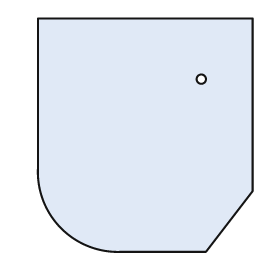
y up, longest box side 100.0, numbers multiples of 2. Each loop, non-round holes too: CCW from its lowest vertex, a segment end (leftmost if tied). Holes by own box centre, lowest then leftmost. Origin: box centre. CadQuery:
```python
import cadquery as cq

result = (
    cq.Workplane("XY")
    .moveTo(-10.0, -50.0)
    .lineTo(26.0, -50.0)
    .lineTo(46.0, -24.0)
    .lineTo(46.0, 50.0)
    .lineTo(-46.0, 50.0)
    .lineTo(-46.0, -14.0)
    .threePointArc((-36.0, -40.0), (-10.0, -50.0))
    .close()
    .moveTo(24.0, 24.0)
    .circle(2.0)
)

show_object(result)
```